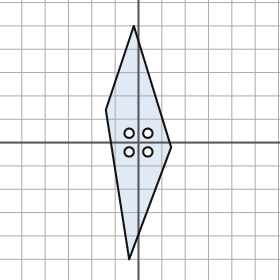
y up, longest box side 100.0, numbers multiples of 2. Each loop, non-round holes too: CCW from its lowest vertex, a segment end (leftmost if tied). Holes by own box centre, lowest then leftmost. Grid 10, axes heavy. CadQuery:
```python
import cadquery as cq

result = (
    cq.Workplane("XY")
    .moveTo(-4.0, -50.0)
    .lineTo(14.0, -2.0)
    .lineTo(-2.0, 50.0)
    .lineTo(-14.0, 14.0)
    .close()
    .moveTo(-4.0, -4.0)
    .circle(2.0)
    .moveTo(4.0, -4.0)
    .circle(2.0)
    .moveTo(-4.0, 4.0)
    .circle(2.0)
    .moveTo(4.0, 4.0)
    .circle(2.0)
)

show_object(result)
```